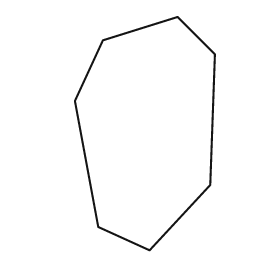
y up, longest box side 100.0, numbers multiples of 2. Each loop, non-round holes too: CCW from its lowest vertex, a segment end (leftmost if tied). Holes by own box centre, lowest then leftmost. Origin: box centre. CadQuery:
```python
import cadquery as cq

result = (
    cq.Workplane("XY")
    .moveTo(2.0, -50.0)
    .lineTo(28.0, -22.0)
    .lineTo(30.0, 34.0)
    .lineTo(14.0, 50.0)
    .lineTo(-18.0, 40.0)
    .lineTo(-30.0, 14.0)
    .lineTo(-20.0, -40.0)
    .close()
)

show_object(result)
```